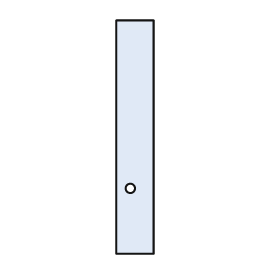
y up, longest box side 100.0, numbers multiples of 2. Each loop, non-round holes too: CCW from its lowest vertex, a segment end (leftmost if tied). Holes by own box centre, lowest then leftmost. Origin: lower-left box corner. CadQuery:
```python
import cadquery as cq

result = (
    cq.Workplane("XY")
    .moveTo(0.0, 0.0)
    .lineTo(16.0, 0.0)
    .lineTo(16.0, 100.0)
    .lineTo(0.0, 100.0)
    .close()
    .moveTo(6.0, 28.0)
    .circle(2.0)
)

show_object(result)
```